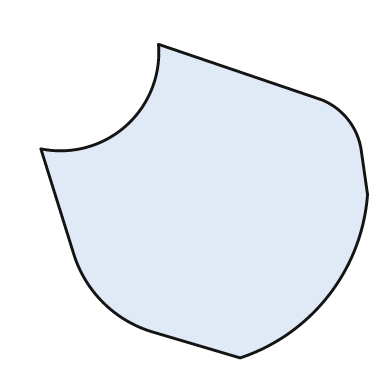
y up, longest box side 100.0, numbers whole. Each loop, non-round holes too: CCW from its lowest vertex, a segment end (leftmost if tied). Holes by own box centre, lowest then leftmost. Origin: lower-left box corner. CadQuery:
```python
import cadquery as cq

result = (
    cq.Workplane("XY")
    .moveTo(61.0, 0.0)
    .threePointArc((88.0, 19.0), (100.0, 50.0))
    .lineTo(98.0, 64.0)
    .threePointArc((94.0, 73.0), (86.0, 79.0))
    .lineTo(36.0, 96.0)
    .threePointArc((26.0, 71.0), (0.0, 64.0))
    .lineTo(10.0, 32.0)
    .threePointArc((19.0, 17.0), (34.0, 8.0))
    .close()
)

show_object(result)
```